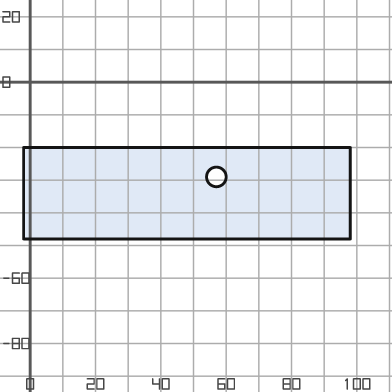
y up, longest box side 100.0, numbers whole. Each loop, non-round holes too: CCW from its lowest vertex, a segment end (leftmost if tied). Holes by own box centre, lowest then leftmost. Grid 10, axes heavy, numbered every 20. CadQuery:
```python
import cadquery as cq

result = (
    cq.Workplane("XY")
    .moveTo(-2.0, -48.0)
    .lineTo(98.0, -48.0)
    .lineTo(98.0, -20.0)
    .lineTo(-2.0, -20.0)
    .close()
    .moveTo(57.0, -29.0)
    .circle(3.0)
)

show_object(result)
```